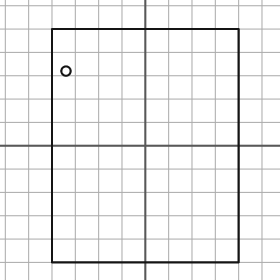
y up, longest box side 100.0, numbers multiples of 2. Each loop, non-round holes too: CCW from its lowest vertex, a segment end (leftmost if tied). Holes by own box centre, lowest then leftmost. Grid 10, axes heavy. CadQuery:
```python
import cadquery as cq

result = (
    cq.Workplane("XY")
    .moveTo(-40.0, -50.0)
    .lineTo(40.0, -50.0)
    .lineTo(40.0, 50.0)
    .lineTo(-40.0, 50.0)
    .close()
    .moveTo(-34.0, 32.0)
    .circle(2.0)
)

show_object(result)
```